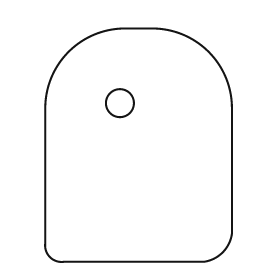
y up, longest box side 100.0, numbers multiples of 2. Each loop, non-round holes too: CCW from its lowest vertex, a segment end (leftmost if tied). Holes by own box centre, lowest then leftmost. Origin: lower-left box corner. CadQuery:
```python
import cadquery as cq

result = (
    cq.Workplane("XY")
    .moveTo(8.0, 0.0)
    .lineTo(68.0, 0.0)
    .threePointArc((76.0, 4.0), (80.0, 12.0))
    .lineTo(80.0, 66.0)
    .threePointArc((70.0, 90.0), (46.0, 100.0))
    .lineTo(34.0, 100.0)
    .threePointArc((10.0, 90.0), (0.0, 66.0))
    .lineTo(0.0, 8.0)
    .threePointArc((2.0, 2.0), (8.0, 0.0))
    .close()
    .moveTo(32.0, 68.0)
    .circle(6.0)
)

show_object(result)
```